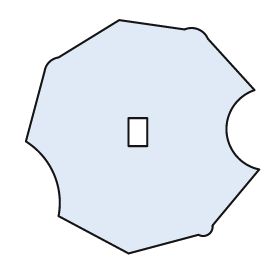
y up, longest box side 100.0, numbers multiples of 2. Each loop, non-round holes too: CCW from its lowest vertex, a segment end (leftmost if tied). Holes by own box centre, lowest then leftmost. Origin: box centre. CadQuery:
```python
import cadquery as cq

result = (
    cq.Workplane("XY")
    .moveTo(-6.0, -50.0)
    .lineTo(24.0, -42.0)
    .threePointArc((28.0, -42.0), (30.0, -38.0))
    .lineTo(50.0, -14.0)
    .threePointArc((36.0, 2.0), (48.0, 20.0))
    .lineTo(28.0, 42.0)
    .threePointArc((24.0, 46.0), (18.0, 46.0))
    .lineTo(-10.0, 50.0)
    .lineTo(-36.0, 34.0)
    .threePointArc((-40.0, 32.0), (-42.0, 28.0))
    .lineTo(-50.0, -2.0)
    .threePointArc((-38.0, -16.0), (-36.0, -34.0))
    .close()
    .moveTo(-6.0, -4.0)
    .lineTo(2.0, -4.0)
    .lineTo(2.0, 8.0)
    .lineTo(-6.0, 8.0)
    .close()
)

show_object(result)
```